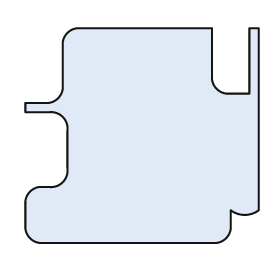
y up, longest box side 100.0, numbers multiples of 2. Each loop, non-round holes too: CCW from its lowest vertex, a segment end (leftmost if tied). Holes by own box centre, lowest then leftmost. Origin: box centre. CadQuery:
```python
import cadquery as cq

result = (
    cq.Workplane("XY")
    .moveTo(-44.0, -46.0)
    .lineTo(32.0, -46.0)
    .threePointArc((36.0, -44.0), (38.0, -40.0))
    .lineTo(38.0, -32.0)
    .threePointArc((44.0, -34.0), (50.0, -32.0))
    .lineTo(50.0, 46.0)
    .lineTo(46.0, 46.0)
    .lineTo(46.0, 18.0)
    .lineTo(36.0, 18.0)
    .threePointArc((32.0, 20.0), (30.0, 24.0))
    .lineTo(30.0, 46.0)
    .lineTo(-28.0, 46.0)
    .threePointArc((-32.0, 44.0), (-34.0, 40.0))
    .lineTo(-34.0, 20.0)
    .threePointArc((-36.0, 16.0), (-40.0, 14.0))
    .lineTo(-50.0, 14.0)
    .lineTo(-50.0, 10.0)
    .lineTo(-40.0, 10.0)
    .threePointArc((-34.0, 8.0), (-32.0, 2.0))
    .lineTo(-32.0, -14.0)
    .threePointArc((-34.0, -20.0), (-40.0, -22.0))
    .lineTo(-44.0, -22.0)
    .threePointArc((-48.0, -24.0), (-50.0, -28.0))
    .lineTo(-50.0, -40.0)
    .threePointArc((-48.0, -44.0), (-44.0, -46.0))
    .close()
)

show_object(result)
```